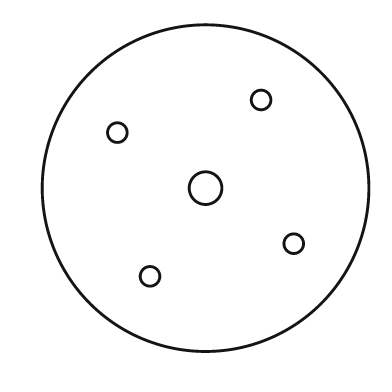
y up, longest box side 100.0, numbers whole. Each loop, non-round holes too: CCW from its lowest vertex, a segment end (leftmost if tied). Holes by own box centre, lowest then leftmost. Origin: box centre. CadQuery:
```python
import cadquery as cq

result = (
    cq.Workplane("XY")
    .moveTo(0.0, 0.0)
    .circle(50.0)
    .moveTo(-17.0, -27.0)
    .circle(3.0)
    .moveTo(27.0, -17.0)
    .circle(3.0)
    .moveTo(0.0, 0.0)
    .circle(5.0)
    .moveTo(-27.0, 17.0)
    .circle(3.0)
    .moveTo(17.0, 27.0)
    .circle(3.0)
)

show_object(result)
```